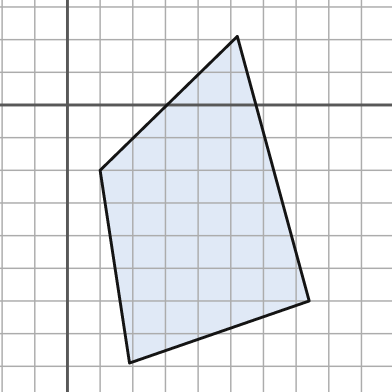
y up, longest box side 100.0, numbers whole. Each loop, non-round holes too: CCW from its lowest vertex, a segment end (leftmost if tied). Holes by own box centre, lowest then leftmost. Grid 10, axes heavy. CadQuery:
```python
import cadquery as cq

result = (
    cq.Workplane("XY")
    .moveTo(19.0, -79.0)
    .lineTo(74.0, -60.0)
    .lineTo(52.0, 21.0)
    .lineTo(10.0, -20.0)
    .close()
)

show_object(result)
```